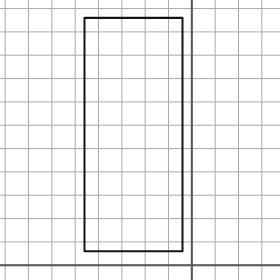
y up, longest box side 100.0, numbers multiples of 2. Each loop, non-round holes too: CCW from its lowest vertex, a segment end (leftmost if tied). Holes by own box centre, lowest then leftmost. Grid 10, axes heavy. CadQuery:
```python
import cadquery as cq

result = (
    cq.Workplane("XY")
    .moveTo(-46.0, 6.0)
    .lineTo(-4.0, 6.0)
    .lineTo(-4.0, 106.0)
    .lineTo(-46.0, 106.0)
    .close()
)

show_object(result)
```